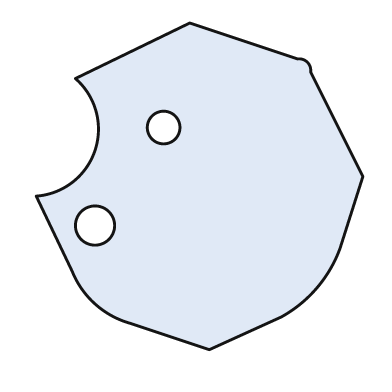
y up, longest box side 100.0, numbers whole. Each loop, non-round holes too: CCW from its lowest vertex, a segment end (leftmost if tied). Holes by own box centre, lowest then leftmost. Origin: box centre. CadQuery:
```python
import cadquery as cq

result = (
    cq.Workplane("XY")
    .moveTo(3.0, -50.0)
    .lineTo(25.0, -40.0)
    .threePointArc((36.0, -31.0), (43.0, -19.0))
    .lineTo(50.0, 3.0)
    .lineTo(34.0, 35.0)
    .threePointArc((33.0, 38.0), (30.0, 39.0))
    .lineTo(-3.0, 50.0)
    .lineTo(-38.0, 33.0)
    .threePointArc((-32.0, 11.0), (-50.0, -3.0))
    .lineTo(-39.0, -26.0)
    .threePointArc((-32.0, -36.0), (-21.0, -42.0))
    .close()
    .moveTo(-32.0, -12.0)
    .circle(6.0)
    .moveTo(-11.0, 18.0)
    .circle(5.0)
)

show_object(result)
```